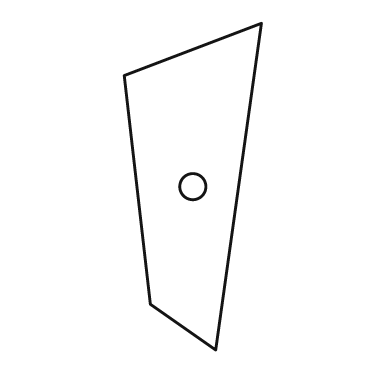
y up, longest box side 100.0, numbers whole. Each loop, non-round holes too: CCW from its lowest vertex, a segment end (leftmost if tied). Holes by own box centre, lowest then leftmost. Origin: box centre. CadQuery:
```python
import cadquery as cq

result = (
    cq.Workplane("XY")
    .moveTo(7.0, -50.0)
    .lineTo(21.0, 50.0)
    .lineTo(-21.0, 34.0)
    .lineTo(-13.0, -36.0)
    .close()
    .moveTo(0.0, 0.0)
    .circle(4.0)
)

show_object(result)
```